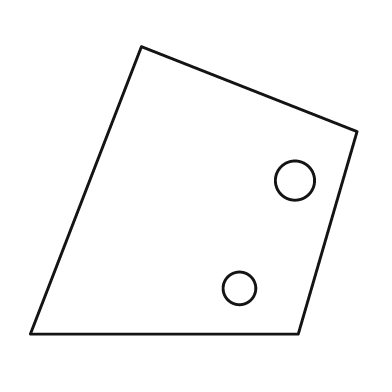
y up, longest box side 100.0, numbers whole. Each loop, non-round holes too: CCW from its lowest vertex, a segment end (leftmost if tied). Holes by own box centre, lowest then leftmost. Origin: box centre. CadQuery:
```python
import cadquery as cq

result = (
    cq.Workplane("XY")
    .moveTo(-50.0, -44.0)
    .lineTo(32.0, -44.0)
    .lineTo(50.0, 18.0)
    .lineTo(-16.0, 44.0)
    .close()
    .moveTo(14.0, -30.0)
    .circle(5.0)
    .moveTo(31.0, 3.0)
    .circle(6.0)
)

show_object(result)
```